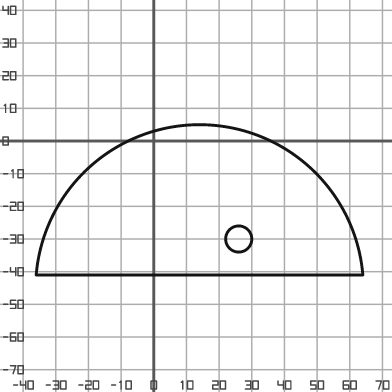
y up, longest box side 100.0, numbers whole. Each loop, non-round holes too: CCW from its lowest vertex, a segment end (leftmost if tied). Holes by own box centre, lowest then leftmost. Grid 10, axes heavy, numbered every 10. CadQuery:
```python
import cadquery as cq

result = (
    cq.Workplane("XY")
    .moveTo(-36.0, -41.0)
    .lineTo(64.0, -41.0)
    .threePointArc((14.0, 5.0), (-36.0, -41.0))
    .close()
    .moveTo(26.0, -30.0)
    .circle(4.0)
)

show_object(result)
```